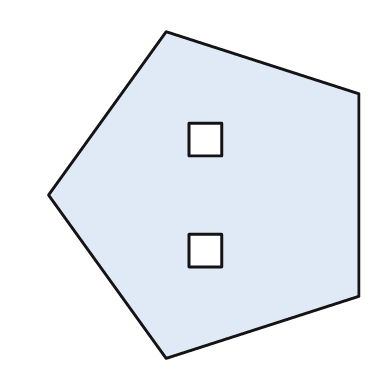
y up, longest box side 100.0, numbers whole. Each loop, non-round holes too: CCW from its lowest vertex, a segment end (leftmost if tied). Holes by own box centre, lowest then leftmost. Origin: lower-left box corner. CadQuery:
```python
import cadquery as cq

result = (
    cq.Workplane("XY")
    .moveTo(36.0, 0.0)
    .lineTo(95.0, 19.0)
    .lineTo(95.0, 81.0)
    .lineTo(36.0, 100.0)
    .lineTo(0.0, 50.0)
    .close()
    .moveTo(43.0, 28.0)
    .lineTo(53.0, 28.0)
    .lineTo(53.0, 38.0)
    .lineTo(43.0, 38.0)
    .close()
    .moveTo(43.0, 62.0)
    .lineTo(53.0, 62.0)
    .lineTo(53.0, 72.0)
    .lineTo(43.0, 72.0)
    .close()
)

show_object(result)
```